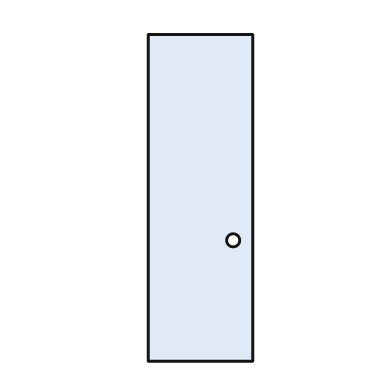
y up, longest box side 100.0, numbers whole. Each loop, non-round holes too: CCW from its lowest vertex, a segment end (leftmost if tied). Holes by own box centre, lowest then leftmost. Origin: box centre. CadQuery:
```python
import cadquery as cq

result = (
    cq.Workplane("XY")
    .moveTo(-16.0, -50.0)
    .lineTo(16.0, -50.0)
    .lineTo(16.0, 50.0)
    .lineTo(-16.0, 50.0)
    .close()
    .moveTo(10.0, -13.0)
    .circle(2.0)
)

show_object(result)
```